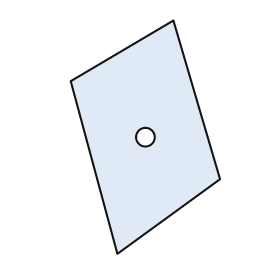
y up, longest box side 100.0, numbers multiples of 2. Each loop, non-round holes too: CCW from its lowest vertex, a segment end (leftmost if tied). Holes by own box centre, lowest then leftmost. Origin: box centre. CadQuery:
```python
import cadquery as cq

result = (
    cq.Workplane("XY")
    .moveTo(-12.0, -50.0)
    .lineTo(32.0, -18.0)
    .lineTo(12.0, 50.0)
    .lineTo(-32.0, 24.0)
    .close()
    .moveTo(0.0, 0.0)
    .circle(4.0)
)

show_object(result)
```